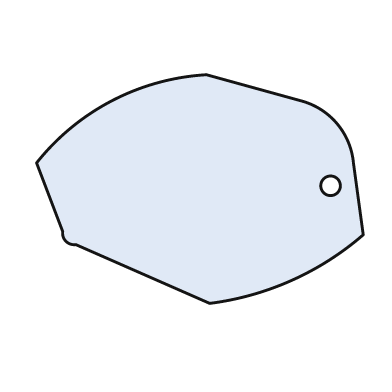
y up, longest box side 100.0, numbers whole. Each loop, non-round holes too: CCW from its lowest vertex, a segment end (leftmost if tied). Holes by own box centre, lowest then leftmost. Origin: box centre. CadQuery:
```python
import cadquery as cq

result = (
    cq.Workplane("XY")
    .moveTo(3.0, -35.0)
    .threePointArc((28.0, -28.0), (50.0, -14.0))
    .lineTo(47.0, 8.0)
    .threePointArc((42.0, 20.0), (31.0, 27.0))
    .lineTo(2.0, 35.0)
    .threePointArc((-27.0, 27.0), (-50.0, 8.0))
    .lineTo(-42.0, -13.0)
    .threePointArc((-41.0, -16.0), (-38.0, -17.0))
    .close()
    .moveTo(40.0, 1.0)
    .circle(3.0)
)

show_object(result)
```